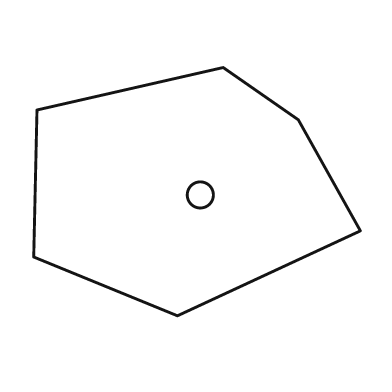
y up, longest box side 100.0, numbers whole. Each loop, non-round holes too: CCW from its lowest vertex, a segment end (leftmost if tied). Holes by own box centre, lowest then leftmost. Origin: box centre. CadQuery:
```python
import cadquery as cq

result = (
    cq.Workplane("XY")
    .moveTo(-6.0, -38.0)
    .lineTo(50.0, -12.0)
    .lineTo(31.0, 22.0)
    .lineTo(8.0, 38.0)
    .lineTo(-49.0, 25.0)
    .lineTo(-50.0, -20.0)
    .close()
    .moveTo(1.0, -1.0)
    .circle(4.0)
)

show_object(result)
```